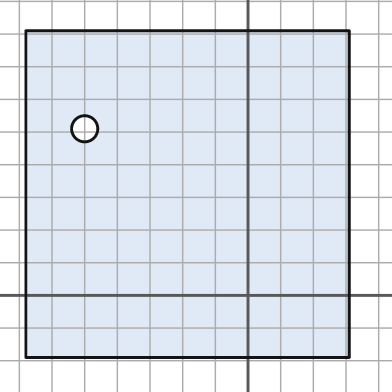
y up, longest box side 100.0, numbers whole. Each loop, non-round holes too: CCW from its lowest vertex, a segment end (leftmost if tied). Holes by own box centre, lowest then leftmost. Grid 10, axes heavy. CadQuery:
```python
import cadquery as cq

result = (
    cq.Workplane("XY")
    .moveTo(-68.0, -19.0)
    .lineTo(31.0, -19.0)
    .lineTo(31.0, 81.0)
    .lineTo(-68.0, 81.0)
    .close()
    .moveTo(-50.0, 51.0)
    .circle(4.0)
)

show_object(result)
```